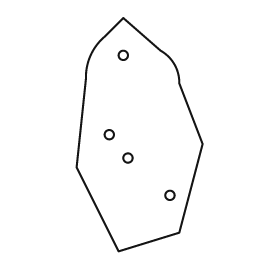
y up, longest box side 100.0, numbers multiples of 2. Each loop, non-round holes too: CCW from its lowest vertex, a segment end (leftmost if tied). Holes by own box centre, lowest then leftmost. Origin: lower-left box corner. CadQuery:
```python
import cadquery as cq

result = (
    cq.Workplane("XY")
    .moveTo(18.0, 0.0)
    .lineTo(44.0, 8.0)
    .lineTo(54.0, 46.0)
    .lineTo(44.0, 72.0)
    .threePointArc((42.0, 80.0), (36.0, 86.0))
    .lineTo(20.0, 100.0)
    .lineTo(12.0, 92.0)
    .threePointArc((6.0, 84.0), (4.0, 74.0))
    .lineTo(0.0, 36.0)
    .close()
    .moveTo(40.0, 24.0)
    .circle(2.0)
    .moveTo(22.0, 40.0)
    .circle(2.0)
    .moveTo(14.0, 50.0)
    .circle(2.0)
    .moveTo(20.0, 84.0)
    .circle(2.0)
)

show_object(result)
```